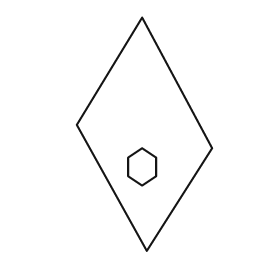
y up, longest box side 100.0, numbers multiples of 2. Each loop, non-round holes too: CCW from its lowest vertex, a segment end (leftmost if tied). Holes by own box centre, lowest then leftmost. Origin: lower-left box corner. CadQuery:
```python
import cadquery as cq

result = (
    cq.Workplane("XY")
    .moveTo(30.0, 0.0)
    .lineTo(58.0, 44.0)
    .lineTo(28.0, 100.0)
    .lineTo(0.0, 54.0)
    .close()
    .moveTo(28.0, 28.0)
    .lineTo(34.0, 32.0)
    .lineTo(34.0, 40.0)
    .lineTo(28.0, 44.0)
    .lineTo(22.0, 40.0)
    .lineTo(22.0, 32.0)
    .close()
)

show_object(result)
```